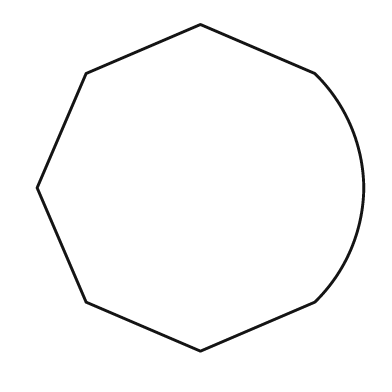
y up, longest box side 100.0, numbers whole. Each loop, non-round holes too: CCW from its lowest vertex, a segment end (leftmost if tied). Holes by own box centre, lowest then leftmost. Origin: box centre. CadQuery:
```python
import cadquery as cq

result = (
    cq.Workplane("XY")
    .moveTo(0.0, -50.0)
    .lineTo(35.0, -35.0)
    .threePointArc((46.0, -19.0), (50.0, 0.0))
    .threePointArc((46.0, 19.0), (35.0, 35.0))
    .lineTo(0.0, 50.0)
    .lineTo(-35.0, 35.0)
    .lineTo(-50.0, 0.0)
    .lineTo(-35.0, -35.0)
    .close()
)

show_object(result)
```